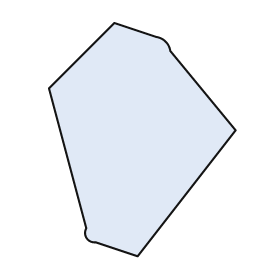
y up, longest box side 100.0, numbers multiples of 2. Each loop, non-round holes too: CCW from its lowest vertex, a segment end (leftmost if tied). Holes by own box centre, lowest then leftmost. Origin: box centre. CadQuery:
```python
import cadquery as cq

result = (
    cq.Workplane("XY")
    .moveTo(-2.0, -50.0)
    .lineTo(40.0, 4.0)
    .lineTo(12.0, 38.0)
    .threePointArc((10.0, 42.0), (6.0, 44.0))
    .lineTo(-12.0, 50.0)
    .lineTo(-40.0, 22.0)
    .lineTo(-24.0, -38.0)
    .threePointArc((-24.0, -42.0), (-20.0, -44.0))
    .close()
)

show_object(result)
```